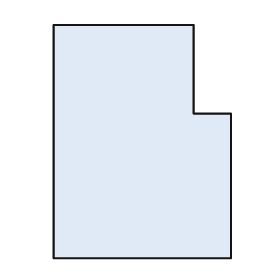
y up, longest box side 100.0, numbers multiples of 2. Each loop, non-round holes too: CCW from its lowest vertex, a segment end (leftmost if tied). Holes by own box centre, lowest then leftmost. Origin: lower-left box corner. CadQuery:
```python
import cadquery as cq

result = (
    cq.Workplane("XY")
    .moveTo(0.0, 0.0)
    .lineTo(76.0, 0.0)
    .lineTo(76.0, 62.0)
    .lineTo(60.0, 62.0)
    .lineTo(60.0, 100.0)
    .lineTo(0.0, 100.0)
    .close()
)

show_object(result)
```